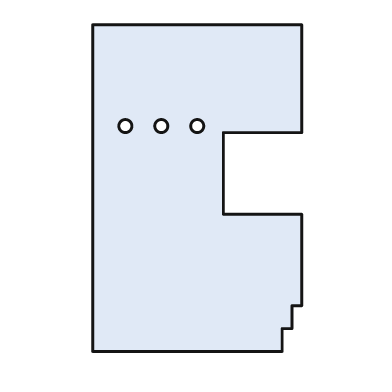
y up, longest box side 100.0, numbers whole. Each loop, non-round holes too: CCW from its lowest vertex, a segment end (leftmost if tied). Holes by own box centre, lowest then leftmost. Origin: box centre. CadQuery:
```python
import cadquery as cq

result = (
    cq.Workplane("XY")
    .moveTo(-32.0, -50.0)
    .lineTo(26.0, -50.0)
    .lineTo(26.0, -43.0)
    .lineTo(29.0, -43.0)
    .lineTo(29.0, -36.0)
    .lineTo(32.0, -36.0)
    .lineTo(32.0, -8.0)
    .lineTo(8.0, -8.0)
    .lineTo(8.0, 17.0)
    .lineTo(32.0, 17.0)
    .lineTo(32.0, 50.0)
    .lineTo(-32.0, 50.0)
    .close()
    .moveTo(-22.0, 19.0)
    .circle(2.0)
    .moveTo(-11.0, 19.0)
    .circle(2.0)
    .moveTo(0.0, 19.0)
    .circle(2.0)
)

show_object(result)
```